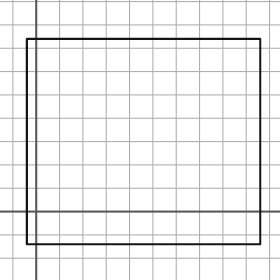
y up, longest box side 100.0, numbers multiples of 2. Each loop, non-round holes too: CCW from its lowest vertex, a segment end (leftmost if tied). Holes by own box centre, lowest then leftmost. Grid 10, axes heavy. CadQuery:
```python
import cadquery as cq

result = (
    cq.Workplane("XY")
    .moveTo(-4.0, -14.0)
    .lineTo(96.0, -14.0)
    .lineTo(96.0, 74.0)
    .lineTo(-4.0, 74.0)
    .close()
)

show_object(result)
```